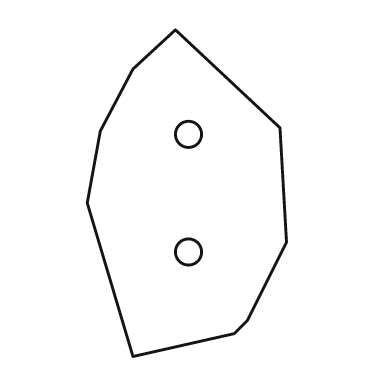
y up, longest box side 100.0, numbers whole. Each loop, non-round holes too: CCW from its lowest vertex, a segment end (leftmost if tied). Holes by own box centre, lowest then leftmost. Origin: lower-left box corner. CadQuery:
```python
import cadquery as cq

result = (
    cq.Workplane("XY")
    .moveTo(14.0, 0.0)
    .lineTo(45.0, 7.0)
    .lineTo(49.0, 11.0)
    .lineTo(61.0, 35.0)
    .lineTo(59.0, 70.0)
    .lineTo(27.0, 100.0)
    .lineTo(14.0, 88.0)
    .lineTo(4.0, 69.0)
    .lineTo(0.0, 47.0)
    .close()
    .moveTo(31.0, 32.0)
    .circle(4.0)
    .moveTo(31.0, 68.0)
    .circle(4.0)
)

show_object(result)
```